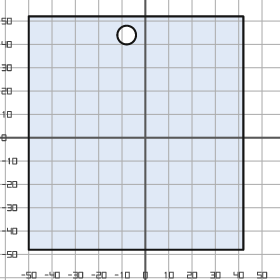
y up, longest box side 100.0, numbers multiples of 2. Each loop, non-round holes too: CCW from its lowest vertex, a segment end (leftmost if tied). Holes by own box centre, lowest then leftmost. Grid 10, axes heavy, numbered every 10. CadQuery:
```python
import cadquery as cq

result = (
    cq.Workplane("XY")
    .moveTo(-50.0, -48.0)
    .lineTo(42.0, -48.0)
    .lineTo(42.0, 52.0)
    .lineTo(-50.0, 52.0)
    .close()
    .moveTo(-8.0, 44.0)
    .circle(4.0)
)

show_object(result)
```